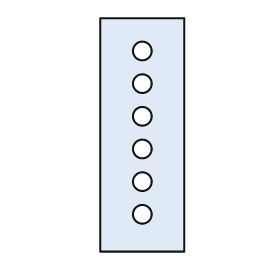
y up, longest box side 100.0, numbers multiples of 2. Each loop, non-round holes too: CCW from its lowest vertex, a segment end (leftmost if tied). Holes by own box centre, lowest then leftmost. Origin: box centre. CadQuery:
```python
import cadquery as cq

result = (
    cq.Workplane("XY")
    .moveTo(-18.0, -50.0)
    .lineTo(18.0, -50.0)
    .lineTo(18.0, 50.0)
    .lineTo(-18.0, 50.0)
    .close()
    .moveTo(0.0, -34.0)
    .circle(4.0)
    .moveTo(0.0, -20.0)
    .circle(4.0)
    .moveTo(0.0, -6.0)
    .circle(4.0)
    .moveTo(0.0, 8.0)
    .circle(4.0)
    .moveTo(0.0, 22.0)
    .circle(4.0)
    .moveTo(0.0, 36.0)
    .circle(4.0)
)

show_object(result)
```